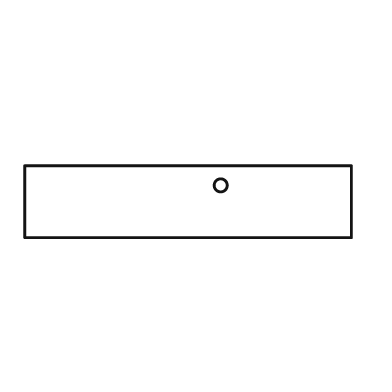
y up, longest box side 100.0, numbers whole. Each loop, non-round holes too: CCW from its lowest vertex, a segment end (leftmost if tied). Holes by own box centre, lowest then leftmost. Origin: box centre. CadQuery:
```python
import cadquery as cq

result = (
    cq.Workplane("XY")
    .moveTo(-50.0, -11.0)
    .lineTo(50.0, -11.0)
    .lineTo(50.0, 11.0)
    .lineTo(-50.0, 11.0)
    .close()
    .moveTo(10.0, 5.0)
    .circle(2.0)
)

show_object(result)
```